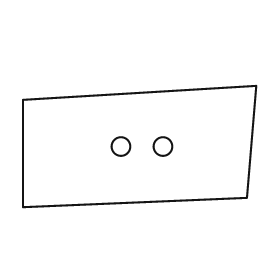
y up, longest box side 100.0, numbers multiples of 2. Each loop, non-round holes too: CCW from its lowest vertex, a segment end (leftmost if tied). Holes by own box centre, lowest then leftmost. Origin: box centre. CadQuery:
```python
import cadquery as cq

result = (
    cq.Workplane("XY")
    .moveTo(-50.0, -26.0)
    .lineTo(46.0, -22.0)
    .lineTo(50.0, 26.0)
    .lineTo(-50.0, 20.0)
    .close()
    .moveTo(-8.0, 0.0)
    .circle(4.0)
    .moveTo(10.0, 0.0)
    .circle(4.0)
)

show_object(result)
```